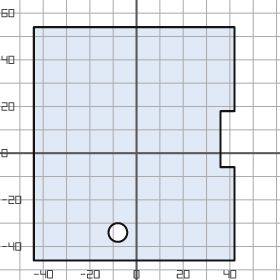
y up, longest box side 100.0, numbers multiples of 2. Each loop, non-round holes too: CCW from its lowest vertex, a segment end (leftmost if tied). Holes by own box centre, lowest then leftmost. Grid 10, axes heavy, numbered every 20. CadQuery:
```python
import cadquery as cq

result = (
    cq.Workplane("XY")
    .moveTo(-44.0, -46.0)
    .lineTo(42.0, -46.0)
    .lineTo(42.0, -6.0)
    .lineTo(36.0, -6.0)
    .lineTo(36.0, 18.0)
    .lineTo(42.0, 18.0)
    .lineTo(42.0, 54.0)
    .lineTo(-44.0, 54.0)
    .close()
    .moveTo(-8.0, -34.0)
    .circle(4.0)
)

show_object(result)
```